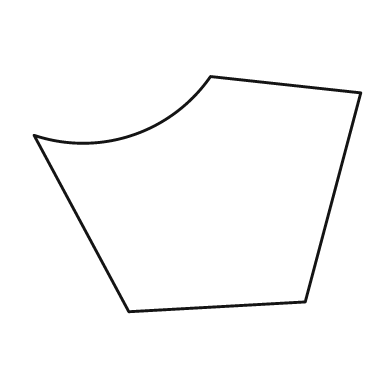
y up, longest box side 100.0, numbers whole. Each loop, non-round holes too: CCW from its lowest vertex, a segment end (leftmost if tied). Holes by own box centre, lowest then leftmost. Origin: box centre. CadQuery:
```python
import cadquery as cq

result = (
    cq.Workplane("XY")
    .moveTo(-21.0, -36.0)
    .lineTo(33.0, -33.0)
    .lineTo(50.0, 31.0)
    .lineTo(4.0, 36.0)
    .threePointArc((-20.0, 18.0), (-50.0, 18.0))
    .close()
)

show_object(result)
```